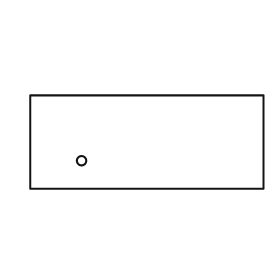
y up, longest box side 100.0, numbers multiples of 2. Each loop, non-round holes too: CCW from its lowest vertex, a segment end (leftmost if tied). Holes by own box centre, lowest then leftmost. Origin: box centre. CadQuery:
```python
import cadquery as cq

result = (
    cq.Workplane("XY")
    .moveTo(-50.0, -20.0)
    .lineTo(50.0, -20.0)
    .lineTo(50.0, 20.0)
    .lineTo(-50.0, 20.0)
    .close()
    .moveTo(-28.0, -8.0)
    .circle(2.0)
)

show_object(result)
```